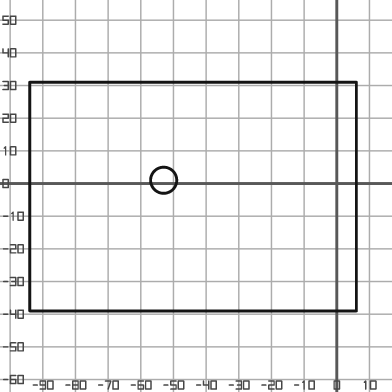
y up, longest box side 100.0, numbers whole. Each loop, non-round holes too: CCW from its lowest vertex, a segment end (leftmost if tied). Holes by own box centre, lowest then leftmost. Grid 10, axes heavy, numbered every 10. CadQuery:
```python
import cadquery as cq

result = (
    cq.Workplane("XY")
    .moveTo(-94.0, -39.0)
    .lineTo(6.0, -39.0)
    .lineTo(6.0, 31.0)
    .lineTo(-94.0, 31.0)
    .close()
    .moveTo(-53.0, 1.0)
    .circle(4.0)
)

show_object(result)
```